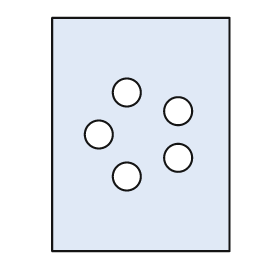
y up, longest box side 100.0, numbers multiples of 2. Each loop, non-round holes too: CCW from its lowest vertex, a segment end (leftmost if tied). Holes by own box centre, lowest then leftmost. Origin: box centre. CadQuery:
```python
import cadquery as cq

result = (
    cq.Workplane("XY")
    .moveTo(-38.0, -50.0)
    .lineTo(38.0, -50.0)
    .lineTo(38.0, 50.0)
    .lineTo(-38.0, 50.0)
    .close()
    .moveTo(-6.0, -18.0)
    .circle(6.0)
    .moveTo(16.0, -10.0)
    .circle(6.0)
    .moveTo(-18.0, 0.0)
    .circle(6.0)
    .moveTo(16.0, 10.0)
    .circle(6.0)
    .moveTo(-6.0, 18.0)
    .circle(6.0)
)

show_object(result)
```